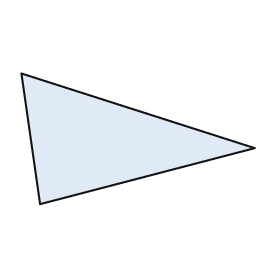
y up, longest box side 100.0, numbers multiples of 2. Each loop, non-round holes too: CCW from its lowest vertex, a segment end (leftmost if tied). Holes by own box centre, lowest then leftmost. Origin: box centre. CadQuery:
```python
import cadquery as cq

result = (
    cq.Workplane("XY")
    .moveTo(-42.0, -28.0)
    .lineTo(50.0, -4.0)
    .lineTo(-50.0, 28.0)
    .close()
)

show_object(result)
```